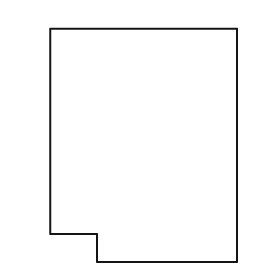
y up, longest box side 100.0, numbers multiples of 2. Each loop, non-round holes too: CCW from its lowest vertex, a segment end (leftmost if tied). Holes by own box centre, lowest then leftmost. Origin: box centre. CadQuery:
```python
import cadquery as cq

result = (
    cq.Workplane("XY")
    .moveTo(-20.0, -50.0)
    .lineTo(40.0, -50.0)
    .lineTo(40.0, 50.0)
    .lineTo(-40.0, 50.0)
    .lineTo(-40.0, -38.0)
    .lineTo(-20.0, -38.0)
    .close()
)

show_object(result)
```